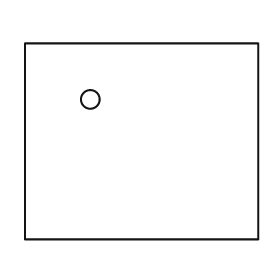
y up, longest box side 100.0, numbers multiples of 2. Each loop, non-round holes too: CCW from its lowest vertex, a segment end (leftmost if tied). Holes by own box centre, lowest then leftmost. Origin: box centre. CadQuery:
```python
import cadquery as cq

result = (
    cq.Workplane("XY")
    .moveTo(-50.0, -42.0)
    .lineTo(50.0, -42.0)
    .lineTo(50.0, 42.0)
    .lineTo(-50.0, 42.0)
    .close()
    .moveTo(-22.0, 18.0)
    .circle(4.0)
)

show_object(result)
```